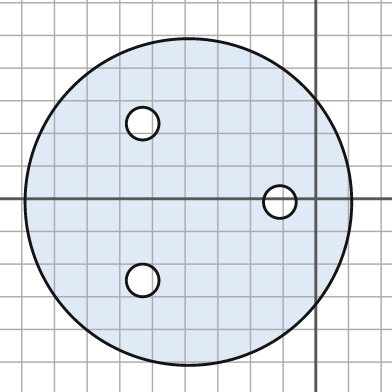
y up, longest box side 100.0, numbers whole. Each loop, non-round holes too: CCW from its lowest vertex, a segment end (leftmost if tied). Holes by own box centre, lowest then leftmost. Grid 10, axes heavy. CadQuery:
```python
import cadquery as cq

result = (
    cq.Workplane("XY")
    .moveTo(-39.0, -1.0)
    .circle(50.0)
    .moveTo(-53.0, -25.0)
    .circle(5.0)
    .moveTo(-11.0, -1.0)
    .circle(5.0)
    .moveTo(-53.0, 23.0)
    .circle(5.0)
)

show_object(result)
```